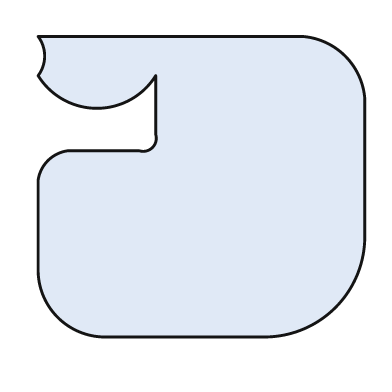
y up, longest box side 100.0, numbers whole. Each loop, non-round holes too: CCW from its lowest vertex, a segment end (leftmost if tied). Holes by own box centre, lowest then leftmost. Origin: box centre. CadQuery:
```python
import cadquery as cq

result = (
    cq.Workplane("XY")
    .moveTo(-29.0, -46.0)
    .lineTo(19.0, -46.0)
    .threePointArc((41.0, -37.0), (50.0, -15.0))
    .lineTo(50.0, 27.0)
    .threePointArc((44.0, 40.0), (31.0, 46.0))
    .lineTo(-50.0, 46.0)
    .threePointArc((-48.0, 40.0), (-50.0, 34.0))
    .threePointArc((-32.0, 24.0), (-14.0, 34.0))
    .lineTo(-14.0, 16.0)
    .threePointArc((-15.0, 12.0), (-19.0, 11.0))
    .lineTo(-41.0, 11.0)
    .threePointArc((-47.0, 8.0), (-50.0, 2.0))
    .lineTo(-50.0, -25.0)
    .threePointArc((-44.0, -40.0), (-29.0, -46.0))
    .close()
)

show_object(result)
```